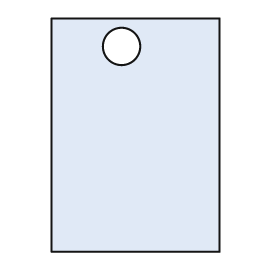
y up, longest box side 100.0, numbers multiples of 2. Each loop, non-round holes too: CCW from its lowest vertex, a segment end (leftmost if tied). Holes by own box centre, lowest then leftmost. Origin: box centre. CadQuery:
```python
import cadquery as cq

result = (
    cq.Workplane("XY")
    .moveTo(-36.0, -50.0)
    .lineTo(36.0, -50.0)
    .lineTo(36.0, 50.0)
    .lineTo(-36.0, 50.0)
    .close()
    .moveTo(-6.0, 38.0)
    .circle(8.0)
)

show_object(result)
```